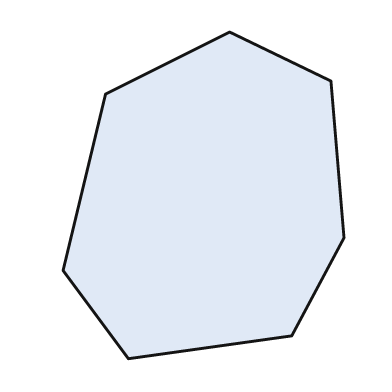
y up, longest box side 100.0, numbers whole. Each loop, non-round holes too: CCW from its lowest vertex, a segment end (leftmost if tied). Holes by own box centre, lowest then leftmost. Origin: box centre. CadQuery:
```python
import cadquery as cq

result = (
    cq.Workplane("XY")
    .moveTo(-23.0, -50.0)
    .lineTo(27.0, -43.0)
    .lineTo(43.0, -13.0)
    .lineTo(39.0, 35.0)
    .lineTo(8.0, 50.0)
    .lineTo(-30.0, 31.0)
    .lineTo(-43.0, -23.0)
    .close()
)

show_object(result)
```